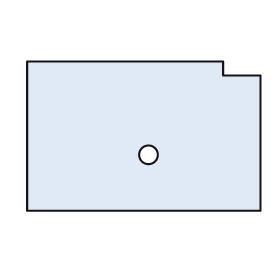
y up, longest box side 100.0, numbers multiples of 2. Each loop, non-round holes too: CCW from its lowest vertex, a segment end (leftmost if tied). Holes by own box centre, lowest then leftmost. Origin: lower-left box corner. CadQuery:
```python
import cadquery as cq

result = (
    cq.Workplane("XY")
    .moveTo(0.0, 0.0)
    .lineTo(100.0, 0.0)
    .lineTo(100.0, 58.0)
    .lineTo(84.0, 58.0)
    .lineTo(84.0, 64.0)
    .lineTo(0.0, 64.0)
    .close()
    .moveTo(52.0, 24.0)
    .circle(4.0)
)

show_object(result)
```